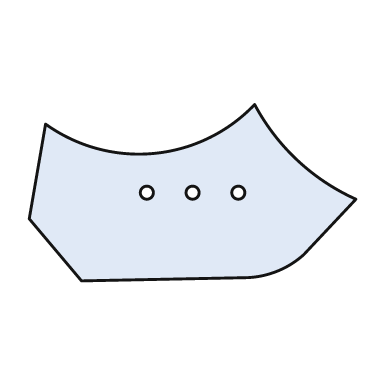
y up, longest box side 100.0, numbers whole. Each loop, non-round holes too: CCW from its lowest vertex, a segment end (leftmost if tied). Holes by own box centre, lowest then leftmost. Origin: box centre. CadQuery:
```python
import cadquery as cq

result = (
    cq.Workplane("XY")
    .moveTo(-34.0, -27.0)
    .lineTo(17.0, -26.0)
    .threePointArc((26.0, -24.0), (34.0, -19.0))
    .lineTo(50.0, -2.0)
    .threePointArc((32.0, 10.0), (19.0, 27.0))
    .threePointArc((-12.0, 12.0), (-45.0, 21.0))
    .lineTo(-50.0, -8.0)
    .close()
    .moveTo(-14.0, 0.0)
    .circle(2.0)
    .moveTo(0.0, 0.0)
    .circle(2.0)
    .moveTo(14.0, 0.0)
    .circle(2.0)
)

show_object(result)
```